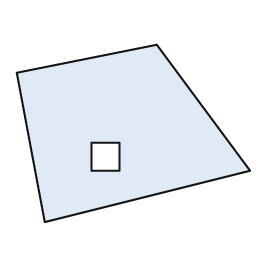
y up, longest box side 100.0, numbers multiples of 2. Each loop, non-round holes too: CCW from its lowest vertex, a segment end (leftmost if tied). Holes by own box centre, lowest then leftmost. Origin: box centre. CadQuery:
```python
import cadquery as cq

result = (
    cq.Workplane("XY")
    .moveTo(-38.0, -38.0)
    .lineTo(50.0, -16.0)
    .lineTo(10.0, 38.0)
    .lineTo(-50.0, 26.0)
    .close()
    .moveTo(-18.0, -16.0)
    .lineTo(-6.0, -16.0)
    .lineTo(-6.0, -4.0)
    .lineTo(-18.0, -4.0)
    .close()
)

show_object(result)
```